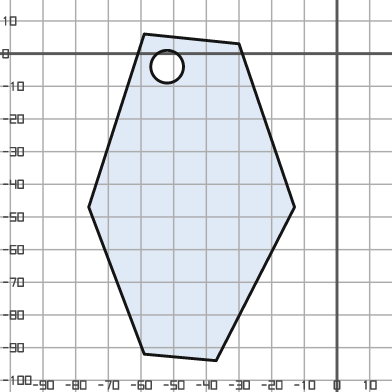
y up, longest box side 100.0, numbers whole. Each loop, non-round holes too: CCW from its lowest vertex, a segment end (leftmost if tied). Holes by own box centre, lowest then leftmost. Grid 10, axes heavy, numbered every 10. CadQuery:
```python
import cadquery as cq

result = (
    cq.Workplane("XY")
    .moveTo(-37.0, -94.0)
    .lineTo(-13.0, -47.0)
    .lineTo(-30.0, 3.0)
    .lineTo(-59.0, 6.0)
    .lineTo(-76.0, -47.0)
    .lineTo(-59.0, -92.0)
    .close()
    .moveTo(-52.0, -4.0)
    .circle(5.0)
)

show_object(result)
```